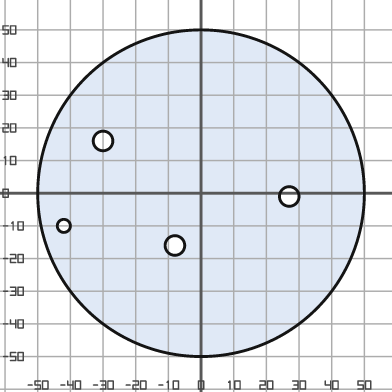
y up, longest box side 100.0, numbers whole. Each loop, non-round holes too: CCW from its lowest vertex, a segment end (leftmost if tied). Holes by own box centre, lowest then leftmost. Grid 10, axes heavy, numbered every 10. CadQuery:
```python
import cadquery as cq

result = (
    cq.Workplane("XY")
    .moveTo(0.0, 0.0)
    .circle(50.0)
    .moveTo(-8.0, -16.0)
    .circle(3.0)
    .moveTo(-42.0, -10.0)
    .circle(2.0)
    .moveTo(27.0, -1.0)
    .circle(3.0)
    .moveTo(-30.0, 16.0)
    .circle(3.0)
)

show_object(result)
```